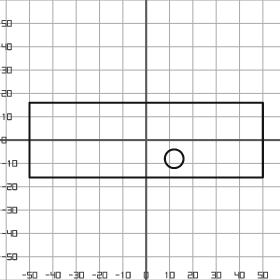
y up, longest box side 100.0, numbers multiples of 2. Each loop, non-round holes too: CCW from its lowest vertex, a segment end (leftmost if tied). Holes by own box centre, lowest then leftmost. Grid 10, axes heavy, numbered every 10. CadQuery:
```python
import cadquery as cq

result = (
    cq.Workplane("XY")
    .moveTo(-50.0, -16.0)
    .lineTo(50.0, -16.0)
    .lineTo(50.0, 16.0)
    .lineTo(-50.0, 16.0)
    .close()
    .moveTo(12.0, -8.0)
    .circle(4.0)
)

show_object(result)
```